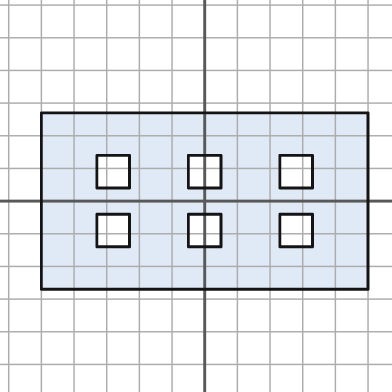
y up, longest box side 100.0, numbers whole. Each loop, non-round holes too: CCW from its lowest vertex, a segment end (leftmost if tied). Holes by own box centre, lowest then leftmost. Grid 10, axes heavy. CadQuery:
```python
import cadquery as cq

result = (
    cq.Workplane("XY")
    .moveTo(-50.0, -27.0)
    .lineTo(50.0, -27.0)
    .lineTo(50.0, 27.0)
    .lineTo(-50.0, 27.0)
    .close()
    .moveTo(-33.0, -14.0)
    .lineTo(-23.0, -14.0)
    .lineTo(-23.0, -4.0)
    .lineTo(-33.0, -4.0)
    .close()
    .moveTo(-5.0, -14.0)
    .lineTo(5.0, -14.0)
    .lineTo(5.0, -4.0)
    .lineTo(-5.0, -4.0)
    .close()
    .moveTo(23.0, -14.0)
    .lineTo(33.0, -14.0)
    .lineTo(33.0, -4.0)
    .lineTo(23.0, -4.0)
    .close()
    .moveTo(-33.0, 4.0)
    .lineTo(-23.0, 4.0)
    .lineTo(-23.0, 14.0)
    .lineTo(-33.0, 14.0)
    .close()
    .moveTo(-5.0, 4.0)
    .lineTo(5.0, 4.0)
    .lineTo(5.0, 14.0)
    .lineTo(-5.0, 14.0)
    .close()
    .moveTo(23.0, 4.0)
    .lineTo(33.0, 4.0)
    .lineTo(33.0, 14.0)
    .lineTo(23.0, 14.0)
    .close()
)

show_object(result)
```